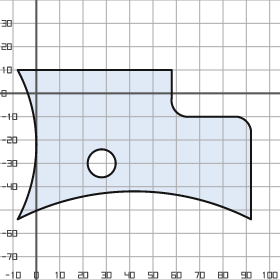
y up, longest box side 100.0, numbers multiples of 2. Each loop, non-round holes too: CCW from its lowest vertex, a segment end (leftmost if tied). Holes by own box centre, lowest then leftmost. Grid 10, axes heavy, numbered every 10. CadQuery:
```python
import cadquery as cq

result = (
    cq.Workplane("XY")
    .moveTo(-8.0, -54.0)
    .threePointArc((42.0, -42.0), (92.0, -54.0))
    .lineTo(92.0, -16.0)
    .threePointArc((90.0, -12.0), (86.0, -10.0))
    .lineTo(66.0, -10.0)
    .threePointArc((60.0, -8.0), (58.0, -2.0))
    .lineTo(58.0, 10.0)
    .lineTo(-8.0, 10.0)
    .threePointArc((0.0, -22.0), (-8.0, -54.0))
    .close()
    .moveTo(28.0, -30.0)
    .circle(6.0)
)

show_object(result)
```